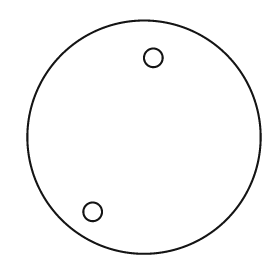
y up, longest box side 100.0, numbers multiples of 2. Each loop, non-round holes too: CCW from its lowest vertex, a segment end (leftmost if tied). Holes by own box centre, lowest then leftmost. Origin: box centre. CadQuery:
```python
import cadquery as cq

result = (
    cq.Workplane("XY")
    .moveTo(0.0, 0.0)
    .circle(50.0)
    .moveTo(-22.0, -32.0)
    .circle(4.0)
    .moveTo(4.0, 34.0)
    .circle(4.0)
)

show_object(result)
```